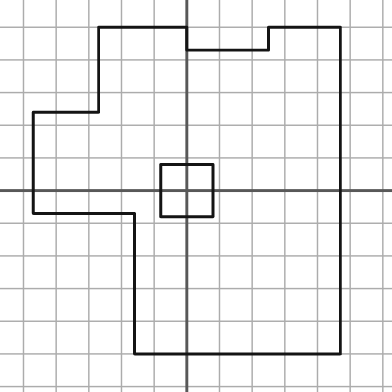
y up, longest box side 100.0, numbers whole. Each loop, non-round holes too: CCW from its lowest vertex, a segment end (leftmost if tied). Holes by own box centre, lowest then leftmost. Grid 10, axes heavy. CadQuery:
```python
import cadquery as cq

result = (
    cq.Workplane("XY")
    .moveTo(-16.0, -50.0)
    .lineTo(47.0, -50.0)
    .lineTo(47.0, 50.0)
    .lineTo(25.0, 50.0)
    .lineTo(25.0, 43.0)
    .lineTo(0.0, 43.0)
    .lineTo(0.0, 50.0)
    .lineTo(-27.0, 50.0)
    .lineTo(-27.0, 24.0)
    .lineTo(-47.0, 24.0)
    .lineTo(-47.0, -7.0)
    .lineTo(-16.0, -7.0)
    .close()
    .moveTo(-8.0, -8.0)
    .lineTo(8.0, -8.0)
    .lineTo(8.0, 8.0)
    .lineTo(-8.0, 8.0)
    .close()
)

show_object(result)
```